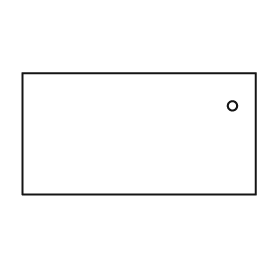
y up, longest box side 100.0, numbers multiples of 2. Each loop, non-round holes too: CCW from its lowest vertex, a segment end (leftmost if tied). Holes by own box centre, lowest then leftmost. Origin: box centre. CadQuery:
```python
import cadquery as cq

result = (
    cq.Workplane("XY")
    .moveTo(-50.0, -26.0)
    .lineTo(50.0, -26.0)
    .lineTo(50.0, 26.0)
    .lineTo(-50.0, 26.0)
    .close()
    .moveTo(40.0, 12.0)
    .circle(2.0)
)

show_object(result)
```